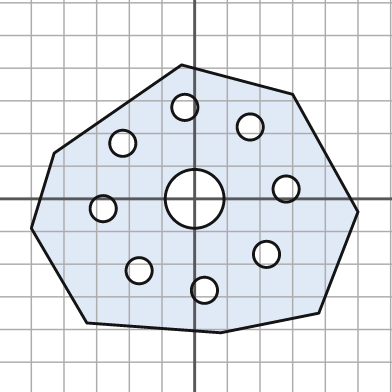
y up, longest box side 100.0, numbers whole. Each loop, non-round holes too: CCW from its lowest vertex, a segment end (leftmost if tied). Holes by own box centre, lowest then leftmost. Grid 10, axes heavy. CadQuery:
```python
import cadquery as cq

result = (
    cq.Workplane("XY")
    .moveTo(8.0, -41.0)
    .lineTo(38.0, -35.0)
    .lineTo(50.0, -4.0)
    .lineTo(30.0, 32.0)
    .lineTo(-4.0, 41.0)
    .lineTo(-43.0, 14.0)
    .lineTo(-50.0, -9.0)
    .lineTo(-33.0, -38.0)
    .close()
    .moveTo(3.0, -28.0)
    .circle(4.0)
    .moveTo(-17.0, -22.0)
    .circle(4.0)
    .moveTo(22.0, -17.0)
    .circle(4.0)
    .moveTo(-28.0, -3.0)
    .circle(4.0)
    .moveTo(0.0, 0.0)
    .circle(9.0)
    .moveTo(28.0, 3.0)
    .circle(4.0)
    .moveTo(-22.0, 17.0)
    .circle(4.0)
    .moveTo(17.0, 22.0)
    .circle(4.0)
    .moveTo(-3.0, 28.0)
    .circle(4.0)
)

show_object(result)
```